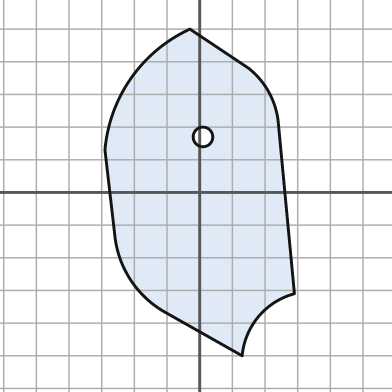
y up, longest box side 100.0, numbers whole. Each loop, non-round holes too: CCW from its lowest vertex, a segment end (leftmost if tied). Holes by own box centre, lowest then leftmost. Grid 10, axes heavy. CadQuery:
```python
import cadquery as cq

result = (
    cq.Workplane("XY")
    .moveTo(13.0, -50.0)
    .threePointArc((18.0, -38.0), (29.0, -31.0))
    .lineTo(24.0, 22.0)
    .threePointArc((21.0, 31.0), (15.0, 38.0))
    .lineTo(-3.0, 50.0)
    .threePointArc((-21.0, 35.0), (-29.0, 13.0))
    .lineTo(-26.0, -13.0)
    .threePointArc((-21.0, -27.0), (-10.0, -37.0))
    .close()
    .moveTo(1.0, 17.0)
    .circle(3.0)
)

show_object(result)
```